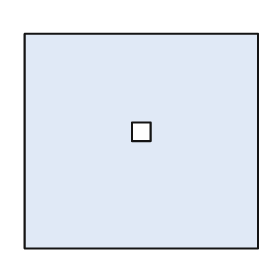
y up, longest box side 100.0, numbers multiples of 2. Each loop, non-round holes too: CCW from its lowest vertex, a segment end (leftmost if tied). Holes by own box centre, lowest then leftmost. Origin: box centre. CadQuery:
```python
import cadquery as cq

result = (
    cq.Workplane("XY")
    .moveTo(-50.0, -46.0)
    .lineTo(50.0, -46.0)
    .lineTo(50.0, 46.0)
    .lineTo(-50.0, 46.0)
    .close()
    .moveTo(-4.0, 0.0)
    .lineTo(4.0, 0.0)
    .lineTo(4.0, 8.0)
    .lineTo(-4.0, 8.0)
    .close()
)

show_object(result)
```